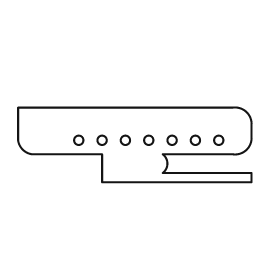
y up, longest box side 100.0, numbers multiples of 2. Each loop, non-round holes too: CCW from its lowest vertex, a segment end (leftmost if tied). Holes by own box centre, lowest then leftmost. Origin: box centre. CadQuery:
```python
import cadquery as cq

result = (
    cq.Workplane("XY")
    .moveTo(-14.0, -16.0)
    .lineTo(50.0, -16.0)
    .lineTo(50.0, -12.0)
    .lineTo(12.0, -12.0)
    .threePointArc((14.0, -8.0), (12.0, -4.0))
    .lineTo(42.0, -4.0)
    .threePointArc((48.0, -2.0), (50.0, 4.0))
    .lineTo(50.0, 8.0)
    .threePointArc((48.0, 14.0), (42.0, 16.0))
    .lineTo(-50.0, 16.0)
    .lineTo(-50.0, 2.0)
    .threePointArc((-48.0, -2.0), (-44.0, -4.0))
    .lineTo(-14.0, -4.0)
    .close()
    .moveTo(-24.0, 2.0)
    .circle(2.0)
    .moveTo(-14.0, 2.0)
    .circle(2.0)
    .moveTo(-4.0, 2.0)
    .circle(2.0)
    .moveTo(6.0, 2.0)
    .circle(2.0)
    .moveTo(16.0, 2.0)
    .circle(2.0)
    .moveTo(26.0, 2.0)
    .circle(2.0)
    .moveTo(36.0, 2.0)
    .circle(2.0)
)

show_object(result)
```